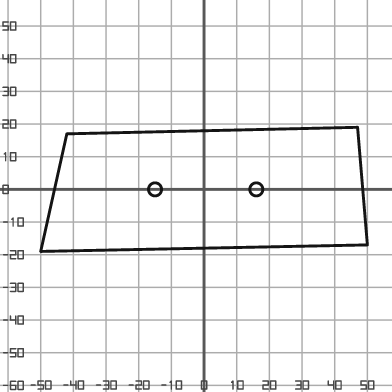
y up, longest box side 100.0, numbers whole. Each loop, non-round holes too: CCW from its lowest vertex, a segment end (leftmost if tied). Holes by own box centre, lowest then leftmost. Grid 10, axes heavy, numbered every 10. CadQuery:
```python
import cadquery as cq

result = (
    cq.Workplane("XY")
    .moveTo(-50.0, -19.0)
    .lineTo(50.0, -17.0)
    .lineTo(47.0, 19.0)
    .lineTo(-42.0, 17.0)
    .close()
    .moveTo(-15.0, 0.0)
    .circle(2.0)
    .moveTo(16.0, 0.0)
    .circle(2.0)
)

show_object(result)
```